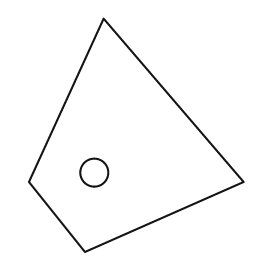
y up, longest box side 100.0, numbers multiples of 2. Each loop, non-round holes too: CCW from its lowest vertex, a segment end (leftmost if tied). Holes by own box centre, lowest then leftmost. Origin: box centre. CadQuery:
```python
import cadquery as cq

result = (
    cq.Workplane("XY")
    .moveTo(-22.0, -50.0)
    .lineTo(46.0, -20.0)
    .lineTo(-14.0, 50.0)
    .lineTo(-46.0, -20.0)
    .close()
    .moveTo(-18.0, -16.0)
    .circle(6.0)
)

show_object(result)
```